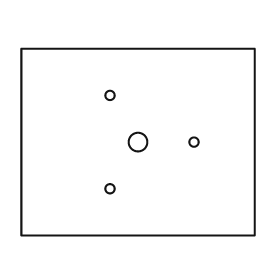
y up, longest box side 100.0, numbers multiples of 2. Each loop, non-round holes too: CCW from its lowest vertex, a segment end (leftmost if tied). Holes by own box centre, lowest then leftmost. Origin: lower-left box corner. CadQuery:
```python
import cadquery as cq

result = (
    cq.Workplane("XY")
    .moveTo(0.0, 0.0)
    .lineTo(100.0, 0.0)
    .lineTo(100.0, 80.0)
    .lineTo(0.0, 80.0)
    .close()
    .moveTo(38.0, 20.0)
    .circle(2.0)
    .moveTo(50.0, 40.0)
    .circle(4.0)
    .moveTo(74.0, 40.0)
    .circle(2.0)
    .moveTo(38.0, 60.0)
    .circle(2.0)
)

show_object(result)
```